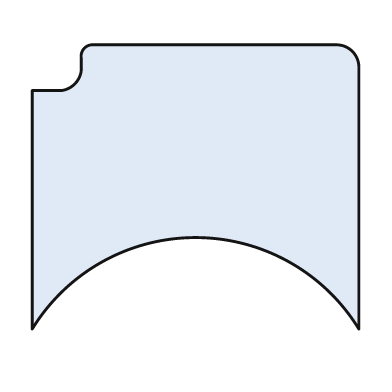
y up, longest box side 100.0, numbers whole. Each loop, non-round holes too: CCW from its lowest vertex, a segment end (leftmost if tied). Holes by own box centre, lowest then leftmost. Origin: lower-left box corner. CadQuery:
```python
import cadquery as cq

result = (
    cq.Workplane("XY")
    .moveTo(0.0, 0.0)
    .threePointArc((50.0, 28.0), (100.0, 0.0))
    .lineTo(100.0, 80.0)
    .threePointArc((98.0, 85.0), (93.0, 87.0))
    .lineTo(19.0, 87.0)
    .threePointArc((16.0, 86.0), (15.0, 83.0))
    .lineTo(15.0, 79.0)
    .threePointArc((13.0, 75.0), (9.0, 73.0))
    .lineTo(0.0, 73.0)
    .close()
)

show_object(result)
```